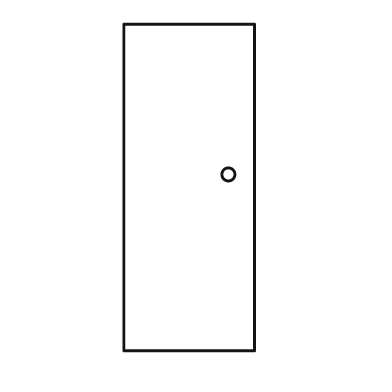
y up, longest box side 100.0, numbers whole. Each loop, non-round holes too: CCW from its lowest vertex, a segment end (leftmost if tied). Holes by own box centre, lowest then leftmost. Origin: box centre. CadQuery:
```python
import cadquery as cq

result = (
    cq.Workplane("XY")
    .moveTo(-20.0, -50.0)
    .lineTo(20.0, -50.0)
    .lineTo(20.0, 50.0)
    .lineTo(-20.0, 50.0)
    .close()
    .moveTo(12.0, 4.0)
    .circle(2.0)
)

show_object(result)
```